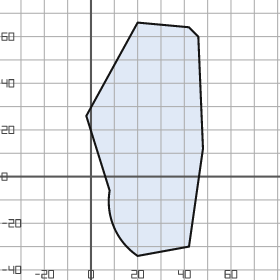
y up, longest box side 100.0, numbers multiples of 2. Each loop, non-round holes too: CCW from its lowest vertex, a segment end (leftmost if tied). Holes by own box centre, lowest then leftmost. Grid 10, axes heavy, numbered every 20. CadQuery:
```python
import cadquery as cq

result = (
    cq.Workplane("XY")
    .moveTo(20.0, -34.0)
    .lineTo(42.0, -30.0)
    .lineTo(48.0, 12.0)
    .lineTo(46.0, 60.0)
    .lineTo(42.0, 64.0)
    .lineTo(20.0, 66.0)
    .lineTo(-2.0, 26.0)
    .lineTo(8.0, -6.0)
    .threePointArc((10.0, -22.0), (20.0, -34.0))
    .close()
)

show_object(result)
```